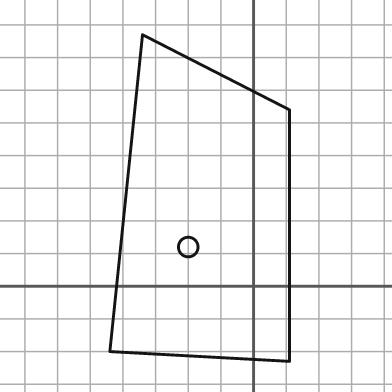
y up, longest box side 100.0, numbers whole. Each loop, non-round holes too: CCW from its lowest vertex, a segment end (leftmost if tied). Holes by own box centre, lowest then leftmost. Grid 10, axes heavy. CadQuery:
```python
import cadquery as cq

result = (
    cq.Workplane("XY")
    .moveTo(11.0, -23.0)
    .lineTo(11.0, 54.0)
    .lineTo(-34.0, 77.0)
    .lineTo(-44.0, -20.0)
    .close()
    .moveTo(-20.0, 12.0)
    .circle(3.0)
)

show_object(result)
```